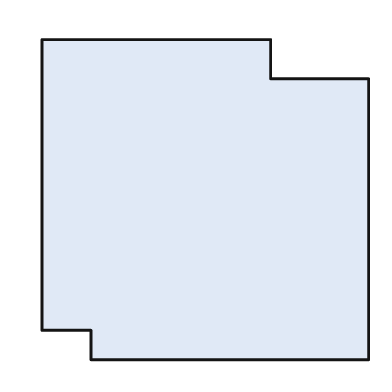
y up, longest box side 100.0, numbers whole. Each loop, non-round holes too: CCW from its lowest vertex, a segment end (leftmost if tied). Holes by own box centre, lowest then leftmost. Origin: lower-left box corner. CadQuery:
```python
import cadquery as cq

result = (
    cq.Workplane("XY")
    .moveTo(15.0, 0.0)
    .lineTo(100.0, 0.0)
    .lineTo(100.0, 86.0)
    .lineTo(70.0, 86.0)
    .lineTo(70.0, 98.0)
    .lineTo(0.0, 98.0)
    .lineTo(0.0, 9.0)
    .lineTo(15.0, 9.0)
    .close()
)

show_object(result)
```